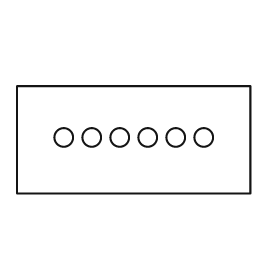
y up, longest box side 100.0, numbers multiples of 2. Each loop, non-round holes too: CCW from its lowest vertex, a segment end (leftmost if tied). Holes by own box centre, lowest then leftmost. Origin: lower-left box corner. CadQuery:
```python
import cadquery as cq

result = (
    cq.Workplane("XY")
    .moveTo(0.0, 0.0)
    .lineTo(100.0, 0.0)
    .lineTo(100.0, 46.0)
    .lineTo(0.0, 46.0)
    .close()
    .moveTo(20.0, 24.0)
    .circle(4.0)
    .moveTo(32.0, 24.0)
    .circle(4.0)
    .moveTo(44.0, 24.0)
    .circle(4.0)
    .moveTo(56.0, 24.0)
    .circle(4.0)
    .moveTo(68.0, 24.0)
    .circle(4.0)
    .moveTo(80.0, 24.0)
    .circle(4.0)
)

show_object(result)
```